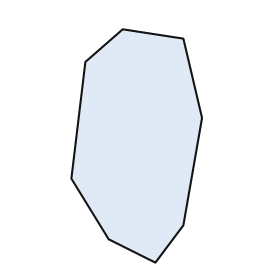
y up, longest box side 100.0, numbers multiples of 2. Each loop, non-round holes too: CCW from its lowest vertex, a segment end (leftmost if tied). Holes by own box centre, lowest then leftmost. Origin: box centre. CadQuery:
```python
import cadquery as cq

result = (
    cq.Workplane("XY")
    .moveTo(8.0, -50.0)
    .lineTo(20.0, -34.0)
    .lineTo(28.0, 12.0)
    .lineTo(20.0, 46.0)
    .lineTo(-6.0, 50.0)
    .lineTo(-22.0, 36.0)
    .lineTo(-28.0, -14.0)
    .lineTo(-12.0, -40.0)
    .close()
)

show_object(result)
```